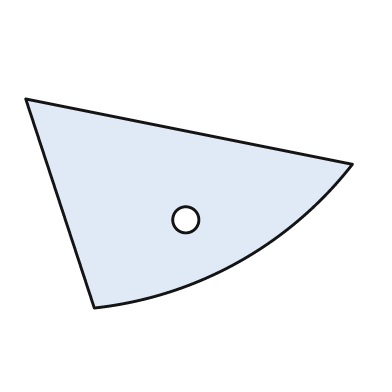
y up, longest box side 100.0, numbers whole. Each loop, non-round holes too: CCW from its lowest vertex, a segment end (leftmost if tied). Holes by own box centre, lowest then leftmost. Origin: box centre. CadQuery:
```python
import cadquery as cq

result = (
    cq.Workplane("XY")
    .moveTo(-29.0, -32.0)
    .threePointArc((15.0, -18.0), (50.0, 12.0))
    .lineTo(-50.0, 32.0)
    .close()
    .moveTo(-1.0, -5.0)
    .circle(4.0)
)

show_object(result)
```